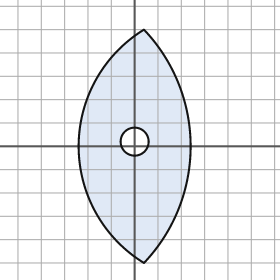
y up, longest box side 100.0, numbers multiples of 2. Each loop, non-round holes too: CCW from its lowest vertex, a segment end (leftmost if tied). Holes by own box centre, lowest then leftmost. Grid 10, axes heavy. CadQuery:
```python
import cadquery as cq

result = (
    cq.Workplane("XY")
    .moveTo(4.0, -50.0)
    .threePointArc((24.0, 0.0), (4.0, 50.0))
    .threePointArc((-24.0, 0.0), (4.0, -50.0))
    .close()
    .moveTo(0.0, 2.0)
    .circle(6.0)
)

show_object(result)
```